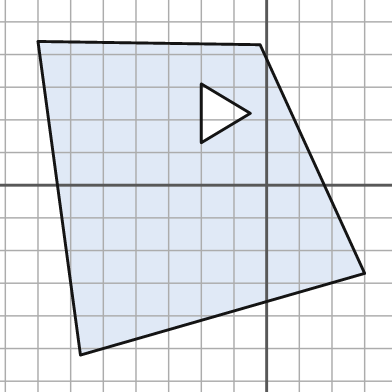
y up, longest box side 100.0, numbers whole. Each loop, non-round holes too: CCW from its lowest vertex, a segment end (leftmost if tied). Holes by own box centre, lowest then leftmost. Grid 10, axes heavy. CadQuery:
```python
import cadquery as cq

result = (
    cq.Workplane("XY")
    .moveTo(-57.0, -52.0)
    .lineTo(30.0, -27.0)
    .lineTo(-2.0, 43.0)
    .lineTo(-70.0, 44.0)
    .close()
    .moveTo(-20.0, 13.0)
    .lineTo(-5.0, 22.0)
    .lineTo(-20.0, 31.0)
    .close()
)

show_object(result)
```